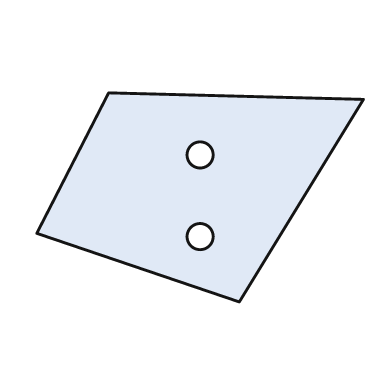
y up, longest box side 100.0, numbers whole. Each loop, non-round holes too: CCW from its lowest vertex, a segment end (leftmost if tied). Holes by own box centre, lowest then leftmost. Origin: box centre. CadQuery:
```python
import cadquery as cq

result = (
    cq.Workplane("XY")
    .moveTo(12.0, -32.0)
    .lineTo(50.0, 30.0)
    .lineTo(-28.0, 32.0)
    .lineTo(-50.0, -11.0)
    .close()
    .moveTo(0.0, -12.0)
    .circle(4.0)
    .moveTo(0.0, 13.0)
    .circle(4.0)
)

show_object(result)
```